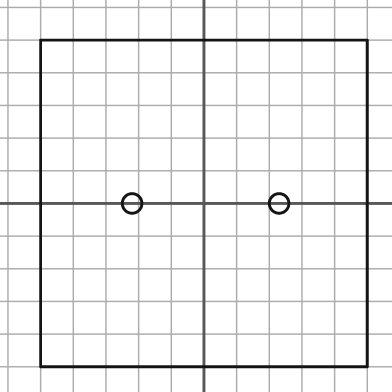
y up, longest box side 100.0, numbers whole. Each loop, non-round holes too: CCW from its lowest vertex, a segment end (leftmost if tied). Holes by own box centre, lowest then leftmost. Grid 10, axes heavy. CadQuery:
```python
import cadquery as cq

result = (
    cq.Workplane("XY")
    .moveTo(-50.0, -50.0)
    .lineTo(50.0, -50.0)
    .lineTo(50.0, 50.0)
    .lineTo(-50.0, 50.0)
    .close()
    .moveTo(-22.0, 0.0)
    .circle(3.0)
    .moveTo(23.0, 0.0)
    .circle(3.0)
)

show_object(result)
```